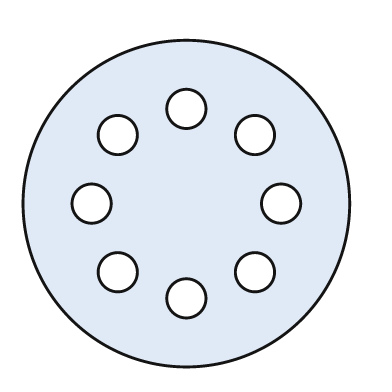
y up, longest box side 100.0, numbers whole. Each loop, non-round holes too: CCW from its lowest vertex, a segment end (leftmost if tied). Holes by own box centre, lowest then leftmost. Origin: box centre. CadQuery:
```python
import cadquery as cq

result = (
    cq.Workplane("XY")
    .moveTo(0.0, 0.0)
    .circle(50.0)
    .moveTo(0.0, -29.0)
    .circle(6.0)
    .moveTo(-21.0, -21.0)
    .circle(6.0)
    .moveTo(21.0, -21.0)
    .circle(6.0)
    .moveTo(-29.0, 0.0)
    .circle(6.0)
    .moveTo(29.0, 0.0)
    .circle(6.0)
    .moveTo(-21.0, 21.0)
    .circle(6.0)
    .moveTo(21.0, 21.0)
    .circle(6.0)
    .moveTo(0.0, 29.0)
    .circle(6.0)
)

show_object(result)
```